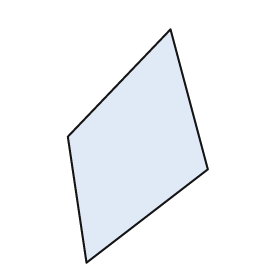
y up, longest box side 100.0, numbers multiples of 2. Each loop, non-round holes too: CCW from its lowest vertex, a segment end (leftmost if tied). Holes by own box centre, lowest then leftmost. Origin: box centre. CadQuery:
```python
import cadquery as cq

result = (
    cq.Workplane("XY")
    .moveTo(-22.0, -50.0)
    .lineTo(30.0, -10.0)
    .lineTo(14.0, 50.0)
    .lineTo(-30.0, 4.0)
    .close()
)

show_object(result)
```